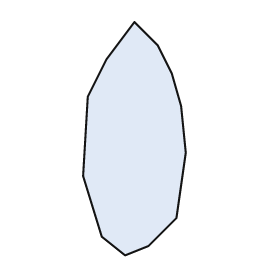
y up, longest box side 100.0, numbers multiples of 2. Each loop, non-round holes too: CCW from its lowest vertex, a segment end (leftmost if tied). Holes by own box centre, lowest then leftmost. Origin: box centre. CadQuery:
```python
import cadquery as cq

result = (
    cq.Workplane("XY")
    .moveTo(-4.0, -50.0)
    .lineTo(6.0, -46.0)
    .lineTo(18.0, -34.0)
    .lineTo(22.0, -6.0)
    .lineTo(20.0, 14.0)
    .lineTo(16.0, 28.0)
    .lineTo(10.0, 40.0)
    .lineTo(0.0, 50.0)
    .lineTo(-12.0, 34.0)
    .lineTo(-20.0, 18.0)
    .lineTo(-22.0, -16.0)
    .lineTo(-14.0, -42.0)
    .close()
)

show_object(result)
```